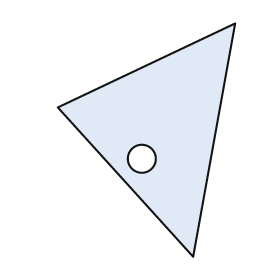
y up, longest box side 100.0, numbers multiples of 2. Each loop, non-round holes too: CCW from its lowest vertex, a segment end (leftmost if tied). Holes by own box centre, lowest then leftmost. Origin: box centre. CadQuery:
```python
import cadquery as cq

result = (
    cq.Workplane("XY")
    .moveTo(20.0, -50.0)
    .lineTo(38.0, 50.0)
    .lineTo(-38.0, 14.0)
    .close()
    .moveTo(-2.0, -8.0)
    .circle(6.0)
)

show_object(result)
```